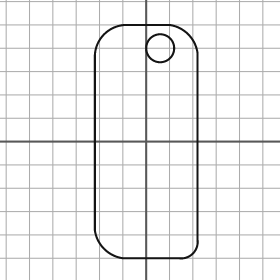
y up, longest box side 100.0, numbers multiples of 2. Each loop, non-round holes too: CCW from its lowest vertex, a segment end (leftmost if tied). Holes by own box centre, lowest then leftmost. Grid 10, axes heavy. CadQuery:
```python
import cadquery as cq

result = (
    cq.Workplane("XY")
    .moveTo(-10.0, -50.0)
    .lineTo(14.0, -50.0)
    .threePointArc((20.0, -48.0), (22.0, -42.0))
    .lineTo(22.0, 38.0)
    .threePointArc((18.0, 46.0), (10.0, 50.0))
    .lineTo(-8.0, 50.0)
    .threePointArc((-18.0, 46.0), (-22.0, 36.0))
    .lineTo(-22.0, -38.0)
    .threePointArc((-18.0, -46.0), (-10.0, -50.0))
    .close()
    .moveTo(6.0, 40.0)
    .circle(6.0)
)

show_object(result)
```